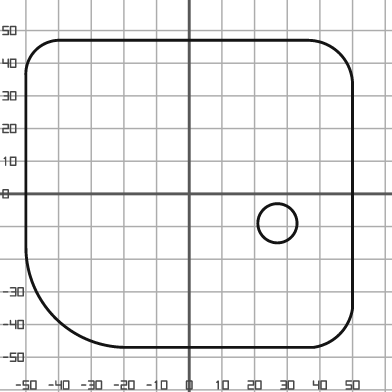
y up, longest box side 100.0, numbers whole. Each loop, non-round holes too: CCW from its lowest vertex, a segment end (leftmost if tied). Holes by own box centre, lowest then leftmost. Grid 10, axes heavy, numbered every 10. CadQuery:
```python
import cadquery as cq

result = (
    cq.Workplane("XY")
    .moveTo(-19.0, -47.0)
    .lineTo(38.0, -47.0)
    .threePointArc((46.0, -43.0), (50.0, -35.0))
    .lineTo(50.0, 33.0)
    .threePointArc((46.0, 43.0), (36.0, 47.0))
    .lineTo(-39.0, 47.0)
    .threePointArc((-47.0, 44.0), (-50.0, 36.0))
    .lineTo(-50.0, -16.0)
    .threePointArc((-41.0, -38.0), (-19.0, -47.0))
    .close()
    .moveTo(27.0, -9.0)
    .circle(6.0)
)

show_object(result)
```